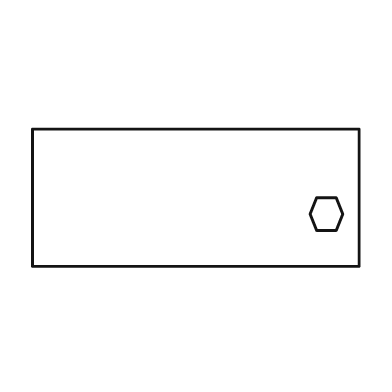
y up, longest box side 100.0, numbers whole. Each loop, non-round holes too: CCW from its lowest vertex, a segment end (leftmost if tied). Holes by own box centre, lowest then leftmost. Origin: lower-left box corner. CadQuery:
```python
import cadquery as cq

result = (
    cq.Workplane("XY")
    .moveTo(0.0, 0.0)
    .lineTo(100.0, 0.0)
    .lineTo(100.0, 42.0)
    .lineTo(0.0, 42.0)
    .close()
    .moveTo(87.0, 11.0)
    .lineTo(93.0, 11.0)
    .lineTo(95.0, 16.0)
    .lineTo(93.0, 21.0)
    .lineTo(87.0, 21.0)
    .lineTo(85.0, 16.0)
    .close()
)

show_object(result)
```